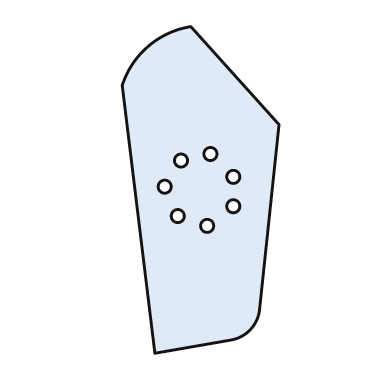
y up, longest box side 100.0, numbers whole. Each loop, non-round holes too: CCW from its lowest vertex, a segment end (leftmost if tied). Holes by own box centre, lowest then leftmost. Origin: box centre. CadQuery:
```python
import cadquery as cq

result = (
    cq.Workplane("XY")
    .moveTo(-14.0, -50.0)
    .lineTo(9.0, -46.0)
    .threePointArc((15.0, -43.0), (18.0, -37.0))
    .lineTo(24.0, 20.0)
    .lineTo(-3.0, 50.0)
    .threePointArc((-16.0, 44.0), (-24.0, 32.0))
    .close()
    .moveTo(2.0, -11.0)
    .circle(2.0)
    .moveTo(-7.0, -8.0)
    .circle(2.0)
    .moveTo(10.0, -5.0)
    .circle(2.0)
    .moveTo(-11.0, 1.0)
    .circle(2.0)
    .moveTo(10.0, 4.0)
    .circle(2.0)
    .moveTo(-6.0, 9.0)
    .circle(2.0)
    .moveTo(3.0, 11.0)
    .circle(2.0)
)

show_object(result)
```